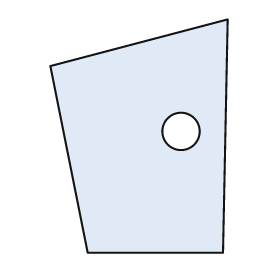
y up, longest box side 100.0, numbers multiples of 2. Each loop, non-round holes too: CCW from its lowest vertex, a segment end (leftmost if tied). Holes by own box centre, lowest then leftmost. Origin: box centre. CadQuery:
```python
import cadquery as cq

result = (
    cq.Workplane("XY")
    .moveTo(-22.0, -50.0)
    .lineTo(36.0, -50.0)
    .lineTo(38.0, 50.0)
    .lineTo(-38.0, 30.0)
    .close()
    .moveTo(18.0, 2.0)
    .circle(8.0)
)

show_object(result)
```